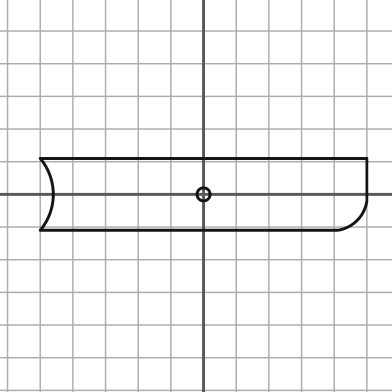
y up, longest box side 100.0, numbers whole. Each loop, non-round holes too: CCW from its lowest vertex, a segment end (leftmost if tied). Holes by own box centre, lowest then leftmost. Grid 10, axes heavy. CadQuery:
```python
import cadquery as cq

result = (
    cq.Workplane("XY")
    .moveTo(-50.0, -11.0)
    .lineTo(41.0, -11.0)
    .threePointArc((47.0, -8.0), (50.0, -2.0))
    .lineTo(50.0, 11.0)
    .lineTo(-50.0, 11.0)
    .threePointArc((-46.0, 0.0), (-50.0, -11.0))
    .close()
    .moveTo(0.0, 0.0)
    .circle(2.0)
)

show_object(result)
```